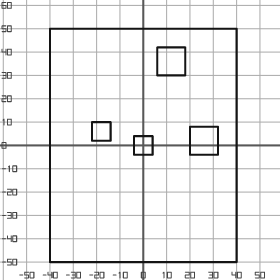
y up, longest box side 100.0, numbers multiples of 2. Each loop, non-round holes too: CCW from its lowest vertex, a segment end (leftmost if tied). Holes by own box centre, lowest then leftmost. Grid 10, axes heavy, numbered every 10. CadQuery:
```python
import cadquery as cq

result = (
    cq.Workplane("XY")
    .moveTo(-40.0, -50.0)
    .lineTo(40.0, -50.0)
    .lineTo(40.0, 50.0)
    .lineTo(-40.0, 50.0)
    .close()
    .moveTo(-4.0, -4.0)
    .lineTo(4.0, -4.0)
    .lineTo(4.0, 4.0)
    .lineTo(-4.0, 4.0)
    .close()
    .moveTo(20.0, -4.0)
    .lineTo(32.0, -4.0)
    .lineTo(32.0, 8.0)
    .lineTo(20.0, 8.0)
    .close()
    .moveTo(-22.0, 2.0)
    .lineTo(-14.0, 2.0)
    .lineTo(-14.0, 10.0)
    .lineTo(-22.0, 10.0)
    .close()
    .moveTo(6.0, 30.0)
    .lineTo(18.0, 30.0)
    .lineTo(18.0, 42.0)
    .lineTo(6.0, 42.0)
    .close()
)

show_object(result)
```